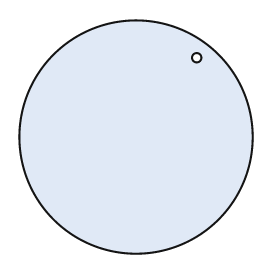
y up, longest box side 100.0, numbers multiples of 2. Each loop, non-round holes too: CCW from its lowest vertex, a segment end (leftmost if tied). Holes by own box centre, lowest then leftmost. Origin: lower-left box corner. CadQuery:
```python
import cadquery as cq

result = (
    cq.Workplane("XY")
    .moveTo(50.0, 50.0)
    .circle(50.0)
    .moveTo(76.0, 84.0)
    .circle(2.0)
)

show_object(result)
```